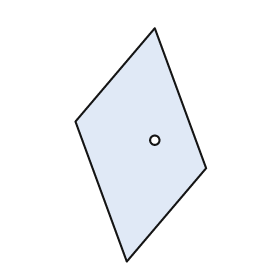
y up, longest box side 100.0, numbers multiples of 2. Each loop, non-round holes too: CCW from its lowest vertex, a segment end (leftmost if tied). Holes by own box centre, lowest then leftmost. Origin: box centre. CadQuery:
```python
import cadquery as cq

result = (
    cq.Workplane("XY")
    .moveTo(-6.0, -50.0)
    .lineTo(28.0, -10.0)
    .lineTo(6.0, 50.0)
    .lineTo(-28.0, 10.0)
    .close()
    .moveTo(6.0, 2.0)
    .circle(2.0)
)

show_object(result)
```